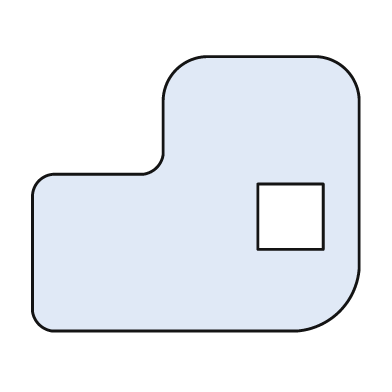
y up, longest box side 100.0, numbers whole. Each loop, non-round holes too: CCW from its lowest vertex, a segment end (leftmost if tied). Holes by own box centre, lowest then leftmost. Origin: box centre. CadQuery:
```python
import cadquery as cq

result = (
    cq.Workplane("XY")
    .moveTo(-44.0, -42.0)
    .lineTo(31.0, -42.0)
    .threePointArc((44.0, -36.0), (50.0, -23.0))
    .lineTo(50.0, 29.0)
    .threePointArc((46.0, 38.0), (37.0, 42.0))
    .lineTo(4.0, 42.0)
    .threePointArc((-6.0, 38.0), (-10.0, 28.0))
    .lineTo(-10.0, 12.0)
    .threePointArc((-12.0, 8.0), (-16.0, 6.0))
    .lineTo(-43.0, 6.0)
    .threePointArc((-48.0, 4.0), (-50.0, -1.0))
    .lineTo(-50.0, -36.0)
    .threePointArc((-48.0, -40.0), (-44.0, -42.0))
    .close()
    .moveTo(19.0, -17.0)
    .lineTo(39.0, -17.0)
    .lineTo(39.0, 3.0)
    .lineTo(19.0, 3.0)
    .close()
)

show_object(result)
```